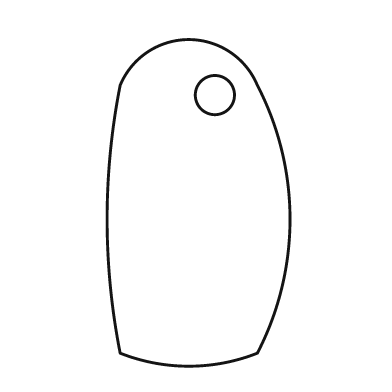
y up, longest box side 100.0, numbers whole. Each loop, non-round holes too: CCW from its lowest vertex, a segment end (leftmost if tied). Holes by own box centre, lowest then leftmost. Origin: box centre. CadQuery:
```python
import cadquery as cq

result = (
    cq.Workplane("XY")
    .moveTo(-24.0, -46.0)
    .threePointArc((-3.0, -50.0), (18.0, -46.0))
    .threePointArc((28.0, -5.0), (18.0, 36.0))
    .threePointArc((-3.0, 50.0), (-24.0, 36.0))
    .threePointArc((-28.0, -5.0), (-24.0, -46.0))
    .close()
    .moveTo(5.0, 33.0)
    .circle(6.0)
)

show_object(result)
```